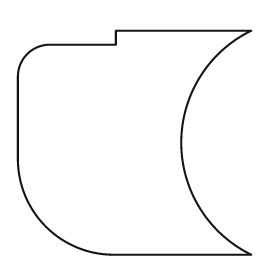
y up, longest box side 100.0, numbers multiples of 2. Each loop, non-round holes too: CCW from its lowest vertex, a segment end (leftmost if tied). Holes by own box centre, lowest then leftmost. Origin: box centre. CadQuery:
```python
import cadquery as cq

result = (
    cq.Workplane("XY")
    .moveTo(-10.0, -48.0)
    .lineTo(50.0, -48.0)
    .threePointArc((20.0, 0.0), (50.0, 48.0))
    .lineTo(-8.0, 48.0)
    .lineTo(-8.0, 42.0)
    .lineTo(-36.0, 42.0)
    .threePointArc((-46.0, 38.0), (-50.0, 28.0))
    .lineTo(-50.0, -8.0)
    .threePointArc((-38.0, -36.0), (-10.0, -48.0))
    .close()
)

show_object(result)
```